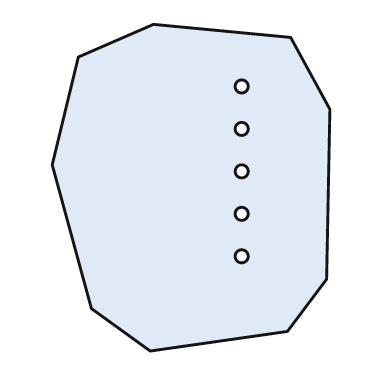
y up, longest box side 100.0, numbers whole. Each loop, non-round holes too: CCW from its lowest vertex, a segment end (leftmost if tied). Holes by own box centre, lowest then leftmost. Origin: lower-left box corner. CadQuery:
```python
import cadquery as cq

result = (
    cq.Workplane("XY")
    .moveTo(30.0, 0.0)
    .lineTo(72.0, 6.0)
    .lineTo(84.0, 22.0)
    .lineTo(85.0, 74.0)
    .lineTo(73.0, 96.0)
    .lineTo(31.0, 100.0)
    .lineTo(8.0, 90.0)
    .lineTo(0.0, 57.0)
    .lineTo(12.0, 13.0)
    .close()
    .moveTo(58.0, 29.0)
    .circle(2.0)
    .moveTo(58.0, 42.0)
    .circle(2.0)
    .moveTo(58.0, 55.0)
    .circle(2.0)
    .moveTo(58.0, 68.0)
    .circle(2.0)
    .moveTo(58.0, 81.0)
    .circle(2.0)
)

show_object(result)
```